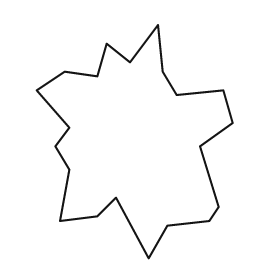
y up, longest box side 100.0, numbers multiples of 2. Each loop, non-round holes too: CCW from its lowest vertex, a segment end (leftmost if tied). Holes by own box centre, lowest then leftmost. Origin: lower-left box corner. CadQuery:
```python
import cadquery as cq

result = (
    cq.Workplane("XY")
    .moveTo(48.0, 0.0)
    .lineTo(56.0, 14.0)
    .lineTo(74.0, 16.0)
    .lineTo(78.0, 22.0)
    .lineTo(70.0, 48.0)
    .lineTo(84.0, 58.0)
    .lineTo(80.0, 72.0)
    .lineTo(60.0, 70.0)
    .lineTo(54.0, 80.0)
    .lineTo(52.0, 100.0)
    .lineTo(40.0, 84.0)
    .lineTo(30.0, 92.0)
    .lineTo(26.0, 78.0)
    .lineTo(12.0, 80.0)
    .lineTo(0.0, 72.0)
    .lineTo(14.0, 56.0)
    .lineTo(8.0, 48.0)
    .lineTo(14.0, 38.0)
    .lineTo(10.0, 16.0)
    .lineTo(26.0, 18.0)
    .lineTo(34.0, 26.0)
    .close()
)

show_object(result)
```